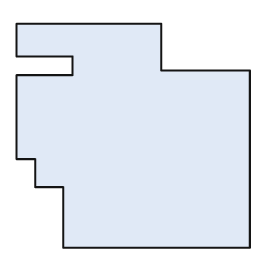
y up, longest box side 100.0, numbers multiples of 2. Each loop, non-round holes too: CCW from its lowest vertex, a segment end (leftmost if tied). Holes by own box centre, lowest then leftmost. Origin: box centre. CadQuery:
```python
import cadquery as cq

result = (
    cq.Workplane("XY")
    .moveTo(-30.0, -48.0)
    .lineTo(50.0, -48.0)
    .lineTo(50.0, 28.0)
    .lineTo(12.0, 28.0)
    .lineTo(12.0, 48.0)
    .lineTo(-50.0, 48.0)
    .lineTo(-50.0, 34.0)
    .lineTo(-26.0, 34.0)
    .lineTo(-26.0, 26.0)
    .lineTo(-50.0, 26.0)
    .lineTo(-50.0, -10.0)
    .lineTo(-42.0, -10.0)
    .lineTo(-42.0, -22.0)
    .lineTo(-30.0, -22.0)
    .close()
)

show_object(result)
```